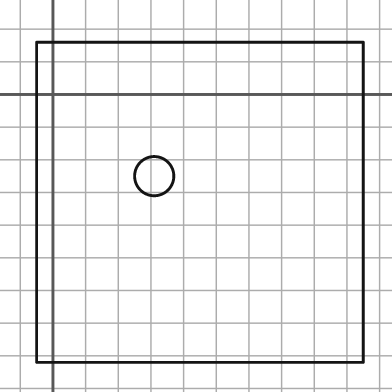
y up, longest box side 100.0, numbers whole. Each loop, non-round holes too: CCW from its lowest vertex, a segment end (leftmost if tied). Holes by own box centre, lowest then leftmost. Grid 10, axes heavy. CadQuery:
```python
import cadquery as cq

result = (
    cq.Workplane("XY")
    .moveTo(-5.0, -82.0)
    .lineTo(95.0, -82.0)
    .lineTo(95.0, 16.0)
    .lineTo(-5.0, 16.0)
    .close()
    .moveTo(31.0, -25.0)
    .circle(6.0)
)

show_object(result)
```